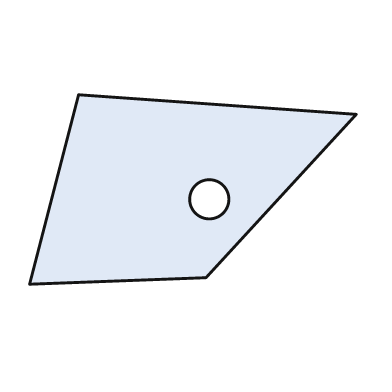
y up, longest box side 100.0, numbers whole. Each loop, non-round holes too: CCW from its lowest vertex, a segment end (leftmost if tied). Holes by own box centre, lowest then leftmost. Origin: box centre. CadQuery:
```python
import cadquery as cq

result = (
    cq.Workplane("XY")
    .moveTo(-50.0, -29.0)
    .lineTo(4.0, -27.0)
    .lineTo(50.0, 23.0)
    .lineTo(-35.0, 29.0)
    .close()
    .moveTo(5.0, -3.0)
    .circle(6.0)
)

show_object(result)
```